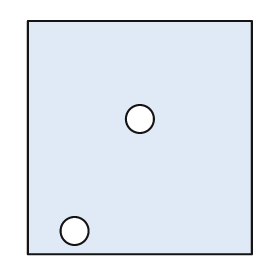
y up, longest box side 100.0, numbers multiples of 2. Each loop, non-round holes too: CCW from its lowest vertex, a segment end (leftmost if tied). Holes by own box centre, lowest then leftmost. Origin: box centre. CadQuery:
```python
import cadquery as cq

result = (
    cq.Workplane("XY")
    .moveTo(-48.0, -50.0)
    .lineTo(48.0, -50.0)
    .lineTo(48.0, 50.0)
    .lineTo(-48.0, 50.0)
    .close()
    .moveTo(-28.0, -40.0)
    .circle(6.0)
    .moveTo(0.0, 8.0)
    .circle(6.0)
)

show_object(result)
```